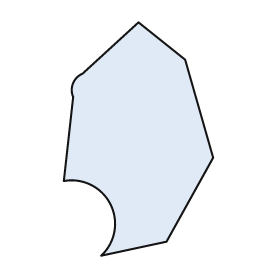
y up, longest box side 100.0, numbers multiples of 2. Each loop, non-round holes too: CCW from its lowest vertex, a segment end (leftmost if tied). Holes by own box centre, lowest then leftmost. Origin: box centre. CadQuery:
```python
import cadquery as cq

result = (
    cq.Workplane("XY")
    .moveTo(-16.0, -50.0)
    .lineTo(12.0, -44.0)
    .lineTo(32.0, -8.0)
    .lineTo(20.0, 34.0)
    .lineTo(0.0, 50.0)
    .lineTo(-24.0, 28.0)
    .threePointArc((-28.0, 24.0), (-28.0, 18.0))
    .lineTo(-32.0, -18.0)
    .threePointArc((-12.0, -28.0), (-16.0, -50.0))
    .close()
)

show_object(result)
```